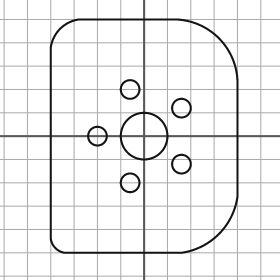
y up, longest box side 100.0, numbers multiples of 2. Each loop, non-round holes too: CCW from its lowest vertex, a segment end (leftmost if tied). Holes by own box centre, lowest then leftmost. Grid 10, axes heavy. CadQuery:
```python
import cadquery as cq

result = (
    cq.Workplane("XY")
    .moveTo(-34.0, -50.0)
    .lineTo(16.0, -50.0)
    .threePointArc((32.0, -42.0), (40.0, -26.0))
    .lineTo(40.0, 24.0)
    .threePointArc((32.0, 42.0), (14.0, 50.0))
    .lineTo(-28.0, 50.0)
    .threePointArc((-36.0, 46.0), (-40.0, 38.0))
    .lineTo(-40.0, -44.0)
    .threePointArc((-38.0, -48.0), (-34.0, -50.0))
    .close()
    .moveTo(-6.0, -20.0)
    .circle(4.0)
    .moveTo(16.0, -12.0)
    .circle(4.0)
    .moveTo(-20.0, 0.0)
    .circle(4.0)
    .moveTo(0.0, 0.0)
    .circle(10.0)
    .moveTo(16.0, 12.0)
    .circle(4.0)
    .moveTo(-6.0, 20.0)
    .circle(4.0)
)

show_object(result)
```